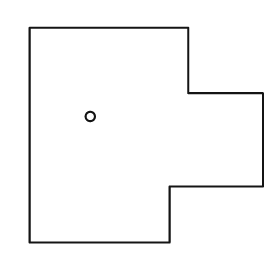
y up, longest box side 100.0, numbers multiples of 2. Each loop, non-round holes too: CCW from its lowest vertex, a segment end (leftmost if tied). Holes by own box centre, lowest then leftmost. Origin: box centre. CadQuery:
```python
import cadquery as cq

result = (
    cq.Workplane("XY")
    .moveTo(-50.0, -46.0)
    .lineTo(10.0, -46.0)
    .lineTo(10.0, -22.0)
    .lineTo(50.0, -22.0)
    .lineTo(50.0, 18.0)
    .lineTo(18.0, 18.0)
    .lineTo(18.0, 46.0)
    .lineTo(-50.0, 46.0)
    .close()
    .moveTo(-24.0, 8.0)
    .circle(2.0)
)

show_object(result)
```